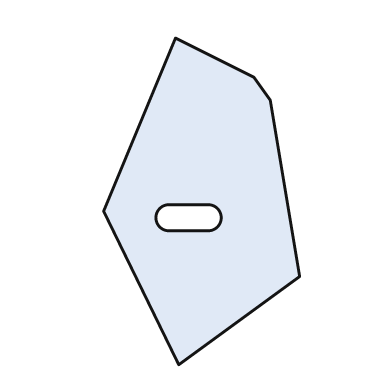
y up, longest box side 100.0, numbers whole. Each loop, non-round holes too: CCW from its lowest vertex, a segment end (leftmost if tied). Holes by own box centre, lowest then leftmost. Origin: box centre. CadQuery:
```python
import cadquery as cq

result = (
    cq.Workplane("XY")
    .moveTo(-7.0, -50.0)
    .lineTo(30.0, -23.0)
    .lineTo(21.0, 31.0)
    .lineTo(16.0, 38.0)
    .lineTo(-8.0, 50.0)
    .lineTo(-30.0, -3.0)
    .close()
    .moveTo(-10.0, -9.0)
    .lineTo(2.0, -9.0)
    .threePointArc((6.0, -5.0), (2.0, -1.0))
    .lineTo(-10.0, -1.0)
    .threePointArc((-14.0, -5.0), (-10.0, -9.0))
    .close()
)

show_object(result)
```